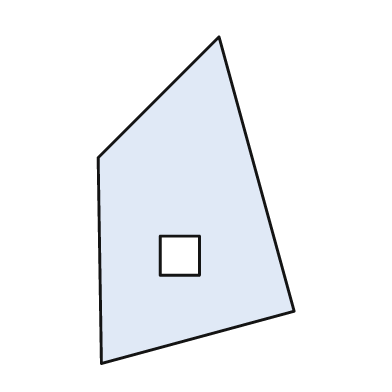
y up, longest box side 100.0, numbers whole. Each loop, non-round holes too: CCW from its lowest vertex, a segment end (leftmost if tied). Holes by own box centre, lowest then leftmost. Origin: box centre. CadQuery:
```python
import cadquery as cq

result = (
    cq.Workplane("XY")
    .moveTo(-29.0, -50.0)
    .lineTo(30.0, -34.0)
    .lineTo(7.0, 50.0)
    .lineTo(-30.0, 13.0)
    .close()
    .moveTo(-11.0, -23.0)
    .lineTo(1.0, -23.0)
    .lineTo(1.0, -11.0)
    .lineTo(-11.0, -11.0)
    .close()
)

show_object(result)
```